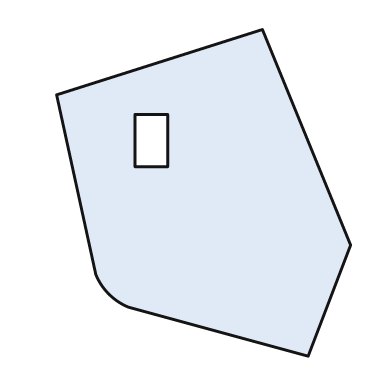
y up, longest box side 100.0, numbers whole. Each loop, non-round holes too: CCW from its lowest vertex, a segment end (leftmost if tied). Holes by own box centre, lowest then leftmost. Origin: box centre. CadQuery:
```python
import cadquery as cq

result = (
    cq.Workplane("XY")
    .moveTo(32.0, -50.0)
    .lineTo(45.0, -16.0)
    .lineTo(18.0, 50.0)
    .lineTo(-45.0, 30.0)
    .lineTo(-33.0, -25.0)
    .threePointArc((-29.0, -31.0), (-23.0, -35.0))
    .close()
    .moveTo(-21.0, 8.0)
    .lineTo(-11.0, 8.0)
    .lineTo(-11.0, 24.0)
    .lineTo(-21.0, 24.0)
    .close()
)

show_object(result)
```